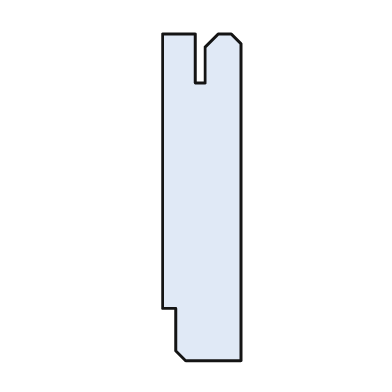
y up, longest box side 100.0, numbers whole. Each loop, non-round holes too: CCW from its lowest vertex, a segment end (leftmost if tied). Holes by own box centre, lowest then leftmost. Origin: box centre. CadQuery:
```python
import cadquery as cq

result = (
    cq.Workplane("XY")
    .moveTo(-5.0, -50.0)
    .lineTo(12.0, -50.0)
    .lineTo(12.0, 47.0)
    .lineTo(9.0, 50.0)
    .lineTo(5.0, 50.0)
    .lineTo(1.0, 46.0)
    .lineTo(1.0, 35.0)
    .lineTo(-2.0, 35.0)
    .lineTo(-2.0, 50.0)
    .lineTo(-12.0, 50.0)
    .lineTo(-12.0, -34.0)
    .lineTo(-8.0, -34.0)
    .lineTo(-8.0, -47.0)
    .close()
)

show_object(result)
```